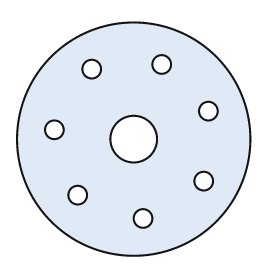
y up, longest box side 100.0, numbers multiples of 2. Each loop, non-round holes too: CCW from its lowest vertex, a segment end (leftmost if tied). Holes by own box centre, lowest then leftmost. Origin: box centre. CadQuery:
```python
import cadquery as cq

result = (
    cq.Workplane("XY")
    .moveTo(0.0, 0.0)
    .circle(50.0)
    .moveTo(4.0, -34.0)
    .circle(4.0)
    .moveTo(-24.0, -24.0)
    .circle(4.0)
    .moveTo(30.0, -18.0)
    .circle(4.0)
    .moveTo(0.0, 0.0)
    .circle(10.0)
    .moveTo(-34.0, 4.0)
    .circle(4.0)
    .moveTo(32.0, 12.0)
    .circle(4.0)
    .moveTo(-18.0, 30.0)
    .circle(4.0)
    .moveTo(12.0, 32.0)
    .circle(4.0)
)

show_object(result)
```